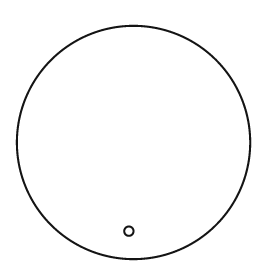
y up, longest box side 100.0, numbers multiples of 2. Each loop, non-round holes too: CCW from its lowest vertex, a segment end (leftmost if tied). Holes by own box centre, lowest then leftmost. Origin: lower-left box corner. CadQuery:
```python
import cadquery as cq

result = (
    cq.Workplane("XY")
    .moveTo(50.0, 50.0)
    .circle(50.0)
    .moveTo(48.0, 12.0)
    .circle(2.0)
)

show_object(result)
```